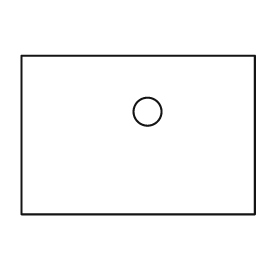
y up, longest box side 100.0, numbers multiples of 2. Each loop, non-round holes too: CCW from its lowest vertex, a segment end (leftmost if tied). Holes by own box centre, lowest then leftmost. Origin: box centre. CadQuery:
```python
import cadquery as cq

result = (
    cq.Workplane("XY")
    .moveTo(-50.0, -34.0)
    .lineTo(50.0, -34.0)
    .lineTo(50.0, 34.0)
    .lineTo(-50.0, 34.0)
    .close()
    .moveTo(4.0, 10.0)
    .circle(6.0)
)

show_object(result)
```